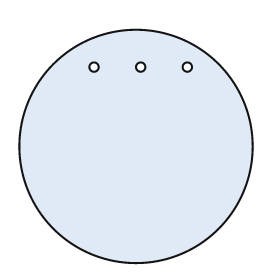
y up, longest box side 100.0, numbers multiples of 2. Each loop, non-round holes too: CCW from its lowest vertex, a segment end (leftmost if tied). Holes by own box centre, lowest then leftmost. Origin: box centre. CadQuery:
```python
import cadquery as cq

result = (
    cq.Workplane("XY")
    .moveTo(0.0, 0.0)
    .circle(50.0)
    .moveTo(-18.0, 34.0)
    .circle(2.0)
    .moveTo(2.0, 34.0)
    .circle(2.0)
    .moveTo(22.0, 34.0)
    .circle(2.0)
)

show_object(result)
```